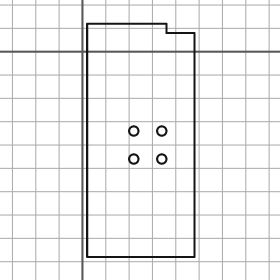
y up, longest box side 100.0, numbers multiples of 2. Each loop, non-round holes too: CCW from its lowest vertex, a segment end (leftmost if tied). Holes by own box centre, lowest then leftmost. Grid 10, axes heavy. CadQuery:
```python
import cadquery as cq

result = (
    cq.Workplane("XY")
    .moveTo(2.0, -88.0)
    .lineTo(48.0, -88.0)
    .lineTo(48.0, 8.0)
    .lineTo(36.0, 8.0)
    .lineTo(36.0, 12.0)
    .lineTo(2.0, 12.0)
    .close()
    .moveTo(22.0, -46.0)
    .circle(2.0)
    .moveTo(34.0, -46.0)
    .circle(2.0)
    .moveTo(22.0, -34.0)
    .circle(2.0)
    .moveTo(34.0, -34.0)
    .circle(2.0)
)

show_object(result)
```